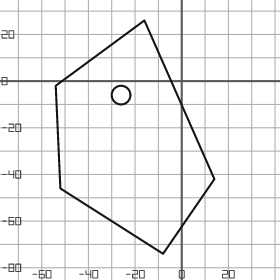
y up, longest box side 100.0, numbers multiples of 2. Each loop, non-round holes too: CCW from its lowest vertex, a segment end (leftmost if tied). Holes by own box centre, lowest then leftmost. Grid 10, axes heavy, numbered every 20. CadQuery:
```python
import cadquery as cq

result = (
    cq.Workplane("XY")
    .moveTo(-8.0, -74.0)
    .lineTo(14.0, -42.0)
    .lineTo(-16.0, 26.0)
    .lineTo(-54.0, -2.0)
    .lineTo(-52.0, -46.0)
    .close()
    .moveTo(-26.0, -6.0)
    .circle(4.0)
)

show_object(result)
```